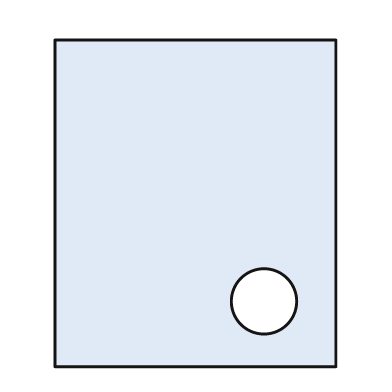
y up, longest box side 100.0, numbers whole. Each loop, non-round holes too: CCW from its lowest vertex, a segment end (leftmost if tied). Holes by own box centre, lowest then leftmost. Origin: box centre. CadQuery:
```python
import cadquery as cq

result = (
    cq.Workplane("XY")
    .moveTo(-43.0, -50.0)
    .lineTo(43.0, -50.0)
    .lineTo(43.0, 50.0)
    .lineTo(-43.0, 50.0)
    .close()
    .moveTo(21.0, -30.0)
    .circle(10.0)
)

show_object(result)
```